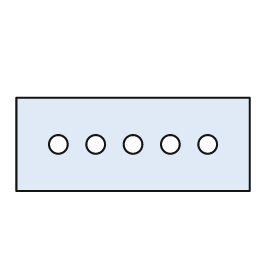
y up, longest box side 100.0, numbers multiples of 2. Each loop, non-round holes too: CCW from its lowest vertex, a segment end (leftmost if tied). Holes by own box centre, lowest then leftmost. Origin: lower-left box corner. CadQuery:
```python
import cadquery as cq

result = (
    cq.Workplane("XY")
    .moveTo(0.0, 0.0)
    .lineTo(100.0, 0.0)
    .lineTo(100.0, 40.0)
    .lineTo(0.0, 40.0)
    .close()
    .moveTo(18.0, 20.0)
    .circle(4.0)
    .moveTo(34.0, 20.0)
    .circle(4.0)
    .moveTo(50.0, 20.0)
    .circle(4.0)
    .moveTo(66.0, 20.0)
    .circle(4.0)
    .moveTo(82.0, 20.0)
    .circle(4.0)
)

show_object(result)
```